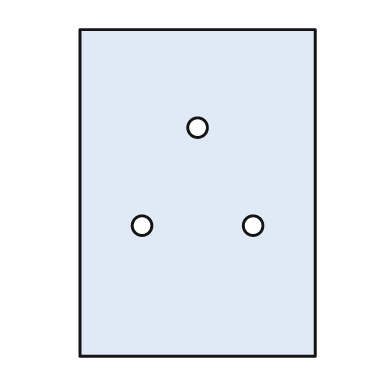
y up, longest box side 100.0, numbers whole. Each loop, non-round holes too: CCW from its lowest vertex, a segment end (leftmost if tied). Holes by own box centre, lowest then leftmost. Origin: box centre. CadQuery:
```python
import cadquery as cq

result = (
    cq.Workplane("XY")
    .moveTo(-36.0, -50.0)
    .lineTo(36.0, -50.0)
    .lineTo(36.0, 50.0)
    .lineTo(-36.0, 50.0)
    .close()
    .moveTo(-17.0, -10.0)
    .circle(3.0)
    .moveTo(17.0, -10.0)
    .circle(3.0)
    .moveTo(0.0, 20.0)
    .circle(3.0)
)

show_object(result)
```